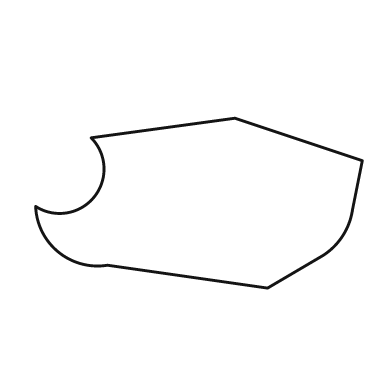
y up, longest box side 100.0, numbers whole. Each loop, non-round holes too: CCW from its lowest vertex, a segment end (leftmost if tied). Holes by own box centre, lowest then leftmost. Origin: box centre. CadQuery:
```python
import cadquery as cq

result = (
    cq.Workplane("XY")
    .moveTo(21.0, -26.0)
    .lineTo(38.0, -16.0)
    .threePointArc((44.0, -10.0), (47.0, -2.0))
    .lineTo(50.0, 13.0)
    .lineTo(11.0, 26.0)
    .lineTo(-33.0, 20.0)
    .threePointArc((-32.0, 2.0), (-50.0, -1.0))
    .threePointArc((-43.0, -15.0), (-28.0, -19.0))
    .close()
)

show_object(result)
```